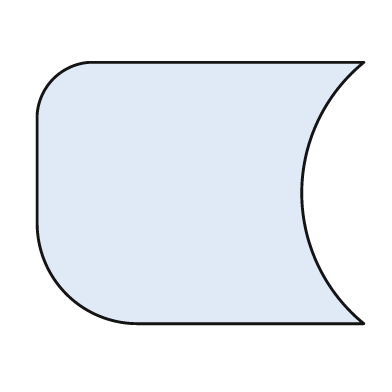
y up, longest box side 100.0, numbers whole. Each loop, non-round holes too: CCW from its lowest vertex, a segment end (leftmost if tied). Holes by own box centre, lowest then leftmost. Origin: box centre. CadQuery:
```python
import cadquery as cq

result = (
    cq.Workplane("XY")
    .moveTo(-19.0, -40.0)
    .lineTo(50.0, -40.0)
    .threePointArc((31.0, 0.0), (50.0, 40.0))
    .lineTo(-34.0, 40.0)
    .threePointArc((-45.0, 35.0), (-50.0, 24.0))
    .lineTo(-50.0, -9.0)
    .threePointArc((-41.0, -31.0), (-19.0, -40.0))
    .close()
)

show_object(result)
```